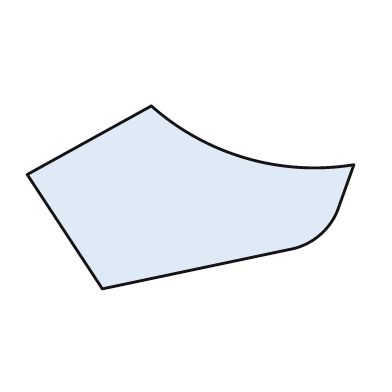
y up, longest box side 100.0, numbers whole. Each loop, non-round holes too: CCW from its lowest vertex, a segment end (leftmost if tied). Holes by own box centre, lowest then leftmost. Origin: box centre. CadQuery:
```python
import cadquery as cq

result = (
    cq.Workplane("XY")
    .moveTo(-27.0, -28.0)
    .lineTo(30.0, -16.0)
    .threePointArc((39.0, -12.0), (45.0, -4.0))
    .lineTo(50.0, 10.0)
    .threePointArc((17.0, 12.0), (-12.0, 28.0))
    .lineTo(-50.0, 7.0)
    .close()
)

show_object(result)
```